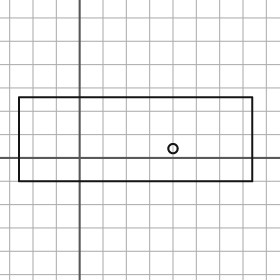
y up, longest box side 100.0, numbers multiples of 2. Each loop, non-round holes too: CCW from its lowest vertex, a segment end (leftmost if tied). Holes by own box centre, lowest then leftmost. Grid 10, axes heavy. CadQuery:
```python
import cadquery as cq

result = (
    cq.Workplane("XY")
    .moveTo(-26.0, -10.0)
    .lineTo(74.0, -10.0)
    .lineTo(74.0, 26.0)
    .lineTo(-26.0, 26.0)
    .close()
    .moveTo(40.0, 4.0)
    .circle(2.0)
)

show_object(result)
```